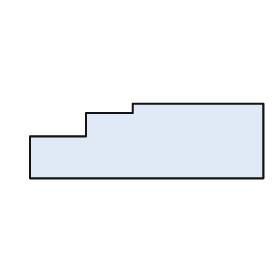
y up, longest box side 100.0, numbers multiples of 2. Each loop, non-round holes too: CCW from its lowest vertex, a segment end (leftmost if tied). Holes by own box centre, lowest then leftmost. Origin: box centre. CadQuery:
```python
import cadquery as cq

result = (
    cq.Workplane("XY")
    .moveTo(-50.0, -16.0)
    .lineTo(50.0, -16.0)
    .lineTo(50.0, 16.0)
    .lineTo(-6.0, 16.0)
    .lineTo(-6.0, 12.0)
    .lineTo(-26.0, 12.0)
    .lineTo(-26.0, 2.0)
    .lineTo(-50.0, 2.0)
    .close()
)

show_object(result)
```